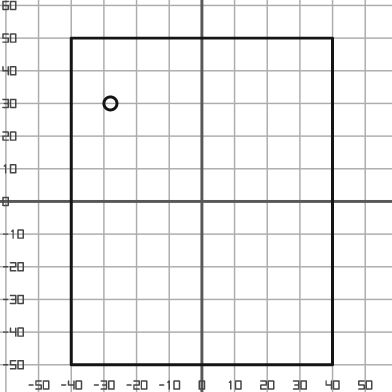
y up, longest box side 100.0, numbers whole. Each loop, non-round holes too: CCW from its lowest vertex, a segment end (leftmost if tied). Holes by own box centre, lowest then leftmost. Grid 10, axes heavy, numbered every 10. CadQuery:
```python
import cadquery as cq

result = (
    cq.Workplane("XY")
    .moveTo(-40.0, -50.0)
    .lineTo(40.0, -50.0)
    .lineTo(40.0, 50.0)
    .lineTo(-40.0, 50.0)
    .close()
    .moveTo(-28.0, 30.0)
    .circle(2.0)
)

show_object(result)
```